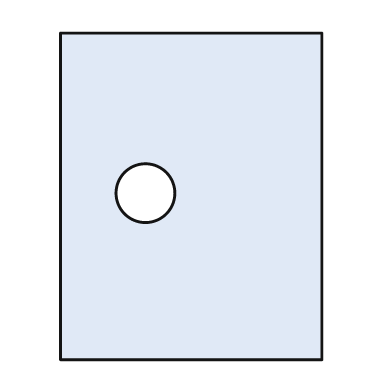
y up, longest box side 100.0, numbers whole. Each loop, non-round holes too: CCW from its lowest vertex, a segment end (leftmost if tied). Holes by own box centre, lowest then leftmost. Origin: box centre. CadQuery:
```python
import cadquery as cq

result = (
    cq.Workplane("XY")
    .moveTo(-40.0, -50.0)
    .lineTo(40.0, -50.0)
    .lineTo(40.0, 50.0)
    .lineTo(-40.0, 50.0)
    .close()
    .moveTo(-14.0, 1.0)
    .circle(9.0)
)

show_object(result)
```